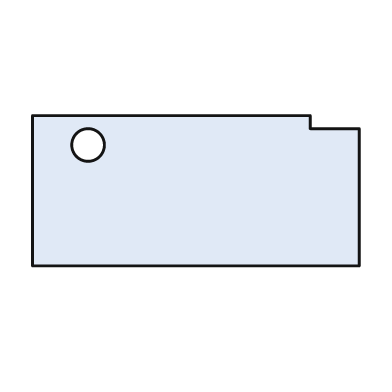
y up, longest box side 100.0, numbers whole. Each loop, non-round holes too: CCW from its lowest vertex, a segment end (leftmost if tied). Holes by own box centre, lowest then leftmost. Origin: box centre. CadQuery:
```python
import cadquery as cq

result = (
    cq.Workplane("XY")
    .moveTo(-50.0, -23.0)
    .lineTo(50.0, -23.0)
    .lineTo(50.0, 19.0)
    .lineTo(35.0, 19.0)
    .lineTo(35.0, 23.0)
    .lineTo(-50.0, 23.0)
    .close()
    .moveTo(-33.0, 14.0)
    .circle(5.0)
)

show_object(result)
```